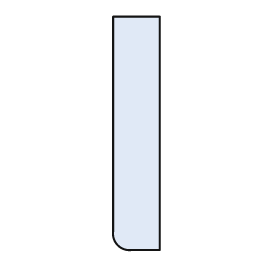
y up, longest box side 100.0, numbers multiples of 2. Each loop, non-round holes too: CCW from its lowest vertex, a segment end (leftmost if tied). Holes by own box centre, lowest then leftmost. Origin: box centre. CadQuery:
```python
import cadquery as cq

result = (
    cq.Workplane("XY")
    .moveTo(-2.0, -50.0)
    .lineTo(10.0, -50.0)
    .lineTo(10.0, 50.0)
    .lineTo(-10.0, 50.0)
    .lineTo(-10.0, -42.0)
    .threePointArc((-8.0, -48.0), (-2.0, -50.0))
    .close()
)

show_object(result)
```